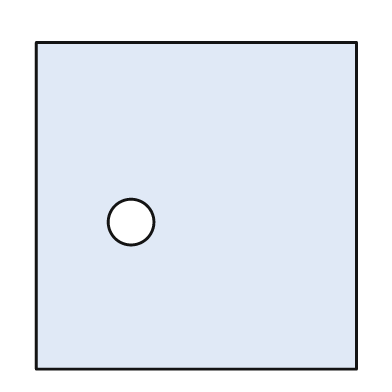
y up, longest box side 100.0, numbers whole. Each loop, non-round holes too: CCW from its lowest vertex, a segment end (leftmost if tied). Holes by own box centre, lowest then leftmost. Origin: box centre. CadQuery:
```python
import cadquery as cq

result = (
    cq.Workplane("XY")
    .moveTo(-49.0, -50.0)
    .lineTo(49.0, -50.0)
    .lineTo(49.0, 50.0)
    .lineTo(-49.0, 50.0)
    .close()
    .moveTo(-20.0, -5.0)
    .circle(7.0)
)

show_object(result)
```